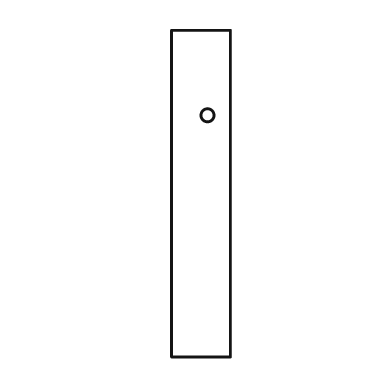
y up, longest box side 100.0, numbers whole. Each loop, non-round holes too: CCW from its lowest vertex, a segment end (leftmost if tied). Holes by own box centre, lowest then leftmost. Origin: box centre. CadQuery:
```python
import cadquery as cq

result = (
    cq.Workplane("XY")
    .moveTo(-9.0, -50.0)
    .lineTo(9.0, -50.0)
    .lineTo(9.0, 50.0)
    .lineTo(-9.0, 50.0)
    .close()
    .moveTo(2.0, 24.0)
    .circle(2.0)
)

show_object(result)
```